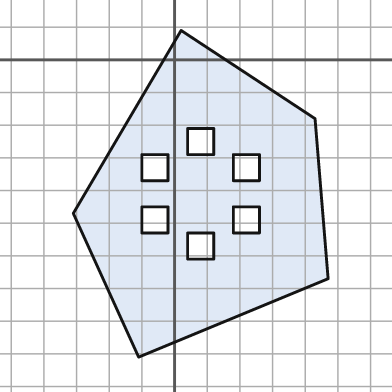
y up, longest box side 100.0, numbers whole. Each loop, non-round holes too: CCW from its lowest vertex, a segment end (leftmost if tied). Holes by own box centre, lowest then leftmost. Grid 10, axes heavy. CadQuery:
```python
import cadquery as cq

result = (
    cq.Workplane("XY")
    .moveTo(-11.0, -91.0)
    .lineTo(47.0, -67.0)
    .lineTo(43.0, -18.0)
    .lineTo(2.0, 9.0)
    .lineTo(-31.0, -47.0)
    .close()
    .moveTo(4.0, -61.0)
    .lineTo(12.0, -61.0)
    .lineTo(12.0, -53.0)
    .lineTo(4.0, -53.0)
    .close()
    .moveTo(-10.0, -53.0)
    .lineTo(-2.0, -53.0)
    .lineTo(-2.0, -45.0)
    .lineTo(-10.0, -45.0)
    .close()
    .moveTo(18.0, -53.0)
    .lineTo(26.0, -53.0)
    .lineTo(26.0, -45.0)
    .lineTo(18.0, -45.0)
    .close()
    .moveTo(-10.0, -37.0)
    .lineTo(-2.0, -37.0)
    .lineTo(-2.0, -29.0)
    .lineTo(-10.0, -29.0)
    .close()
    .moveTo(18.0, -37.0)
    .lineTo(26.0, -37.0)
    .lineTo(26.0, -29.0)
    .lineTo(18.0, -29.0)
    .close()
    .moveTo(4.0, -29.0)
    .lineTo(12.0, -29.0)
    .lineTo(12.0, -21.0)
    .lineTo(4.0, -21.0)
    .close()
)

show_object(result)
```